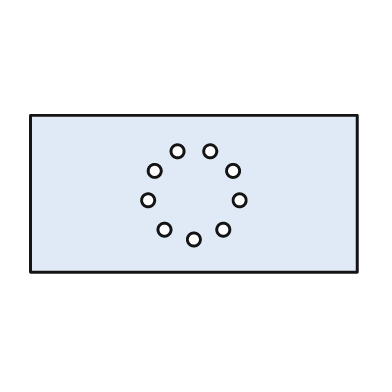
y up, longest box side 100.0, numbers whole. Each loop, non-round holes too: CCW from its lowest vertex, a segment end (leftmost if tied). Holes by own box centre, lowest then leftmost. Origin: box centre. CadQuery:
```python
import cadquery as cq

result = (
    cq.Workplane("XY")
    .moveTo(-50.0, -24.0)
    .lineTo(50.0, -24.0)
    .lineTo(50.0, 24.0)
    .lineTo(-50.0, 24.0)
    .close()
    .moveTo(0.0, -14.0)
    .circle(2.0)
    .moveTo(-9.0, -11.0)
    .circle(2.0)
    .moveTo(9.0, -11.0)
    .circle(2.0)
    .moveTo(-14.0, -2.0)
    .circle(2.0)
    .moveTo(14.0, -2.0)
    .circle(2.0)
    .moveTo(-12.0, 7.0)
    .circle(2.0)
    .moveTo(12.0, 7.0)
    .circle(2.0)
    .moveTo(-5.0, 13.0)
    .circle(2.0)
    .moveTo(5.0, 13.0)
    .circle(2.0)
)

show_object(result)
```